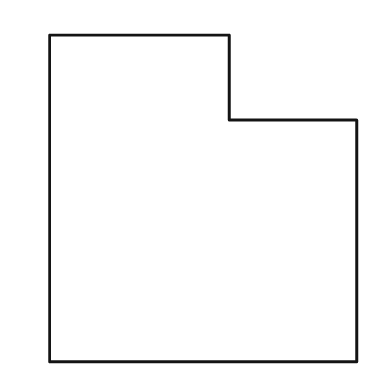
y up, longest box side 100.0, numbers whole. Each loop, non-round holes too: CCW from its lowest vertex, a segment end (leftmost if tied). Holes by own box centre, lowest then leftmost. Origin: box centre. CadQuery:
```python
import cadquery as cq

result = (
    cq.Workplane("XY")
    .moveTo(-47.0, -50.0)
    .lineTo(47.0, -50.0)
    .lineTo(47.0, 24.0)
    .lineTo(8.0, 24.0)
    .lineTo(8.0, 50.0)
    .lineTo(-47.0, 50.0)
    .close()
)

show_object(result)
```